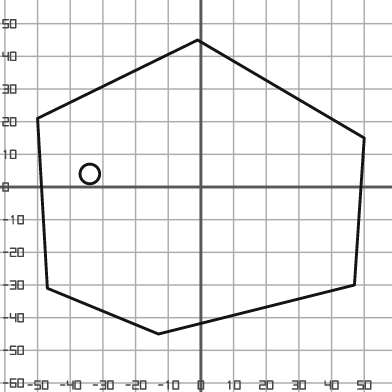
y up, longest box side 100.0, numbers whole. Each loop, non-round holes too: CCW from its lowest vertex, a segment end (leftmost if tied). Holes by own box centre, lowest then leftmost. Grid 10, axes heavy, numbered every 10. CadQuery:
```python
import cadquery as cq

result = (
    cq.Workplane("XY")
    .moveTo(-13.0, -45.0)
    .lineTo(47.0, -30.0)
    .lineTo(50.0, 15.0)
    .lineTo(-1.0, 45.0)
    .lineTo(-50.0, 21.0)
    .lineTo(-47.0, -31.0)
    .close()
    .moveTo(-34.0, 4.0)
    .circle(3.0)
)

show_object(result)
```